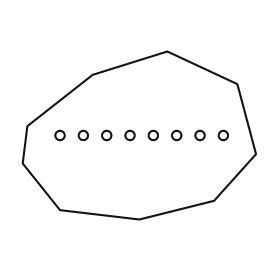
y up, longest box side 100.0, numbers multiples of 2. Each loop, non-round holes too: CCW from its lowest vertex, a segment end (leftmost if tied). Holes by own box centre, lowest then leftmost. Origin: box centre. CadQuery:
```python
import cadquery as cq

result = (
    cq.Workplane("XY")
    .moveTo(0.0, -36.0)
    .lineTo(32.0, -28.0)
    .lineTo(50.0, -8.0)
    .lineTo(42.0, 22.0)
    .lineTo(12.0, 36.0)
    .lineTo(-20.0, 26.0)
    .lineTo(-48.0, 4.0)
    .lineTo(-50.0, -12.0)
    .lineTo(-34.0, -32.0)
    .close()
    .moveTo(-34.0, 0.0)
    .circle(2.0)
    .moveTo(-24.0, 0.0)
    .circle(2.0)
    .moveTo(-14.0, 0.0)
    .circle(2.0)
    .moveTo(-4.0, 0.0)
    .circle(2.0)
    .moveTo(6.0, 0.0)
    .circle(2.0)
    .moveTo(16.0, 0.0)
    .circle(2.0)
    .moveTo(26.0, 0.0)
    .circle(2.0)
    .moveTo(36.0, 0.0)
    .circle(2.0)
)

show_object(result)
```